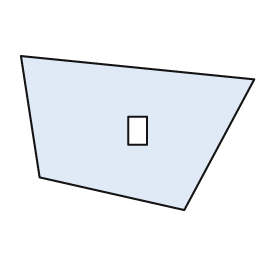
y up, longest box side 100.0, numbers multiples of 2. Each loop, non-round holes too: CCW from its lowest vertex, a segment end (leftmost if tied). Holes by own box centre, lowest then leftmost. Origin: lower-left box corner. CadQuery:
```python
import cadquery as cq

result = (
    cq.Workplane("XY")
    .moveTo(70.0, 0.0)
    .lineTo(100.0, 56.0)
    .lineTo(0.0, 66.0)
    .lineTo(8.0, 14.0)
    .close()
    .moveTo(46.0, 28.0)
    .lineTo(54.0, 28.0)
    .lineTo(54.0, 40.0)
    .lineTo(46.0, 40.0)
    .close()
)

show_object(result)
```